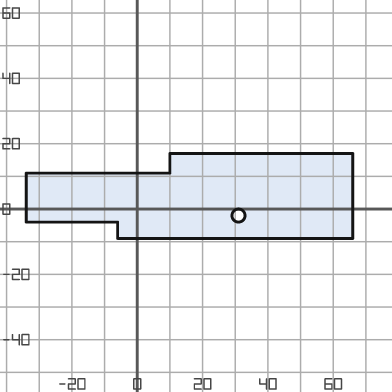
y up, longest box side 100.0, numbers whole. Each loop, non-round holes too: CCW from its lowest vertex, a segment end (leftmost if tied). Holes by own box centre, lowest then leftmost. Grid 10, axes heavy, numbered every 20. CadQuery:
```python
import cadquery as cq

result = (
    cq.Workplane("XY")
    .moveTo(-6.0, -9.0)
    .lineTo(66.0, -9.0)
    .lineTo(66.0, 17.0)
    .lineTo(10.0, 17.0)
    .lineTo(10.0, 11.0)
    .lineTo(-34.0, 11.0)
    .lineTo(-34.0, -4.0)
    .lineTo(-6.0, -4.0)
    .close()
    .moveTo(31.0, -2.0)
    .circle(2.0)
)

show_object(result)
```